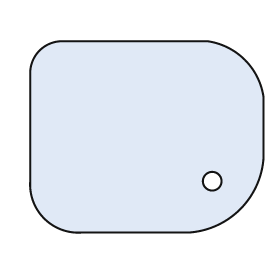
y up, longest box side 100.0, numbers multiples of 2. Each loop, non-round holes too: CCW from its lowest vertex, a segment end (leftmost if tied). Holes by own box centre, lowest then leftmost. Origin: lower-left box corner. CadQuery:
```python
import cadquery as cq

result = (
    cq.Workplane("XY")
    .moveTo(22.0, 0.0)
    .lineTo(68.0, 0.0)
    .threePointArc((90.0, 10.0), (100.0, 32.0))
    .lineTo(100.0, 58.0)
    .threePointArc((92.0, 74.0), (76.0, 82.0))
    .lineTo(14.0, 82.0)
    .threePointArc((4.0, 78.0), (0.0, 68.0))
    .lineTo(0.0, 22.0)
    .threePointArc((6.0, 6.0), (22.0, 0.0))
    .close()
    .moveTo(78.0, 22.0)
    .circle(4.0)
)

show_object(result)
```